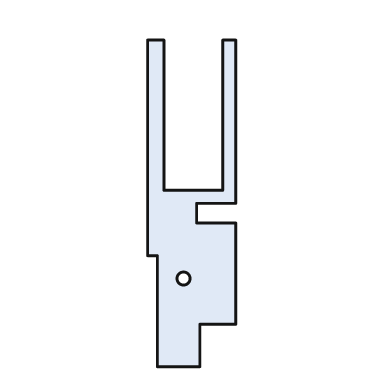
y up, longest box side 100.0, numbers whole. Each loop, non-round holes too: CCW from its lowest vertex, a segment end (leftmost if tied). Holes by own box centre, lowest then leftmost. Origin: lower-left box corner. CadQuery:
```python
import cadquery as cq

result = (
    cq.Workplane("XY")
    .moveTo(3.0, 0.0)
    .lineTo(16.0, 0.0)
    .lineTo(16.0, 13.0)
    .lineTo(27.0, 13.0)
    .lineTo(27.0, 44.0)
    .lineTo(15.0, 44.0)
    .lineTo(15.0, 50.0)
    .lineTo(27.0, 50.0)
    .lineTo(27.0, 100.0)
    .lineTo(23.0, 100.0)
    .lineTo(23.0, 54.0)
    .lineTo(5.0, 54.0)
    .lineTo(5.0, 100.0)
    .lineTo(0.0, 100.0)
    .lineTo(0.0, 34.0)
    .lineTo(3.0, 34.0)
    .close()
    .moveTo(11.0, 27.0)
    .circle(2.0)
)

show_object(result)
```